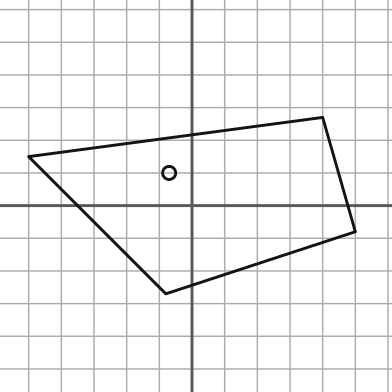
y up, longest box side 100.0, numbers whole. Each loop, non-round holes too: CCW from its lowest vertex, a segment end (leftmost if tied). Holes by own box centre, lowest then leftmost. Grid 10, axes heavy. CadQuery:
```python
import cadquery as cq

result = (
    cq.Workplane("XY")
    .moveTo(-8.0, -27.0)
    .lineTo(50.0, -8.0)
    .lineTo(40.0, 27.0)
    .lineTo(-50.0, 15.0)
    .close()
    .moveTo(-7.0, 10.0)
    .circle(2.0)
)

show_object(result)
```